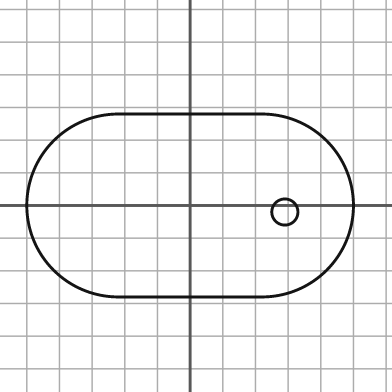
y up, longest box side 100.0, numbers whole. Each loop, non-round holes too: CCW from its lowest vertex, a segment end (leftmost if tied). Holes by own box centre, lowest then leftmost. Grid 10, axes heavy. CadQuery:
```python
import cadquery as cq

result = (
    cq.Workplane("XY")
    .moveTo(-22.0, -28.0)
    .lineTo(22.0, -28.0)
    .threePointArc((50.0, 0.0), (22.0, 28.0))
    .lineTo(-22.0, 28.0)
    .threePointArc((-50.0, 0.0), (-22.0, -28.0))
    .close()
    .moveTo(29.0, -2.0)
    .circle(4.0)
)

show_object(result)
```